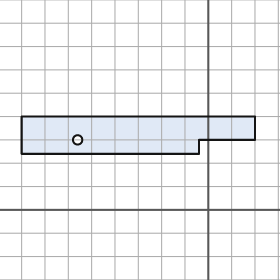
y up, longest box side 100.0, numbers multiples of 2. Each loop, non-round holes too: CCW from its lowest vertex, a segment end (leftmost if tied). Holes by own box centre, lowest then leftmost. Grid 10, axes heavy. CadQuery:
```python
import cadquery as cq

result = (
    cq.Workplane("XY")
    .moveTo(-80.0, 24.0)
    .lineTo(-4.0, 24.0)
    .lineTo(-4.0, 30.0)
    .lineTo(20.0, 30.0)
    .lineTo(20.0, 40.0)
    .lineTo(-80.0, 40.0)
    .close()
    .moveTo(-56.0, 30.0)
    .circle(2.0)
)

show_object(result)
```